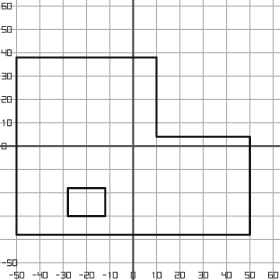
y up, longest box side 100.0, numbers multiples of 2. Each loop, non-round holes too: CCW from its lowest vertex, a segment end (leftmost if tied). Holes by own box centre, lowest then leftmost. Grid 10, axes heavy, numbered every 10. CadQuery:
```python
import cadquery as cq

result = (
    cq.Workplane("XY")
    .moveTo(-50.0, -38.0)
    .lineTo(50.0, -38.0)
    .lineTo(50.0, 4.0)
    .lineTo(10.0, 4.0)
    .lineTo(10.0, 38.0)
    .lineTo(-50.0, 38.0)
    .close()
    .moveTo(-28.0, -30.0)
    .lineTo(-12.0, -30.0)
    .lineTo(-12.0, -18.0)
    .lineTo(-28.0, -18.0)
    .close()
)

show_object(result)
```